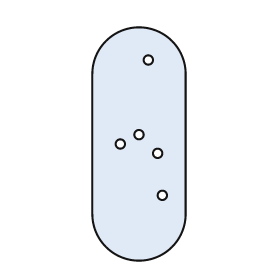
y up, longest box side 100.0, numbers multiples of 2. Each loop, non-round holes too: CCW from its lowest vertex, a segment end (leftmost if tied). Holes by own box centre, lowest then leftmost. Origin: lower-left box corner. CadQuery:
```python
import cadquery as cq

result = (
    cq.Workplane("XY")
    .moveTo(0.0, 20.0)
    .threePointArc((20.0, 0.0), (40.0, 20.0))
    .lineTo(40.0, 80.0)
    .threePointArc((20.0, 100.0), (0.0, 80.0))
    .close()
    .moveTo(30.0, 28.0)
    .circle(2.0)
    .moveTo(28.0, 46.0)
    .circle(2.0)
    .moveTo(12.0, 50.0)
    .circle(2.0)
    .moveTo(20.0, 54.0)
    .circle(2.0)
    .moveTo(24.0, 86.0)
    .circle(2.0)
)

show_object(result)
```